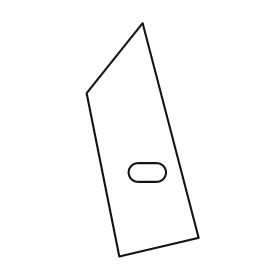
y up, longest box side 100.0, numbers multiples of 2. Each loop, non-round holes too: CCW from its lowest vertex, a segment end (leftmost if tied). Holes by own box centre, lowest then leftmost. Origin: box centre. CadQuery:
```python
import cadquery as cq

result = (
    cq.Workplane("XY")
    .moveTo(-10.0, -50.0)
    .lineTo(24.0, -42.0)
    .lineTo(0.0, 50.0)
    .lineTo(-24.0, 20.0)
    .close()
    .moveTo(-2.0, -18.0)
    .lineTo(6.0, -18.0)
    .threePointArc((10.0, -14.0), (6.0, -10.0))
    .lineTo(-2.0, -10.0)
    .threePointArc((-6.0, -14.0), (-2.0, -18.0))
    .close()
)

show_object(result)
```